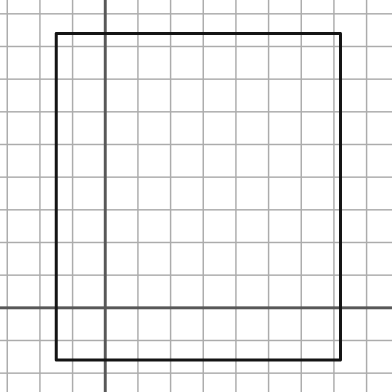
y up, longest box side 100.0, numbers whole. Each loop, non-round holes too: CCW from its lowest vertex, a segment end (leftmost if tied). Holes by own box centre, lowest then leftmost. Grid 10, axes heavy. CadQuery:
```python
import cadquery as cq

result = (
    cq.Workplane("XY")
    .moveTo(-15.0, -16.0)
    .lineTo(72.0, -16.0)
    .lineTo(72.0, 84.0)
    .lineTo(-15.0, 84.0)
    .close()
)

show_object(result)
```